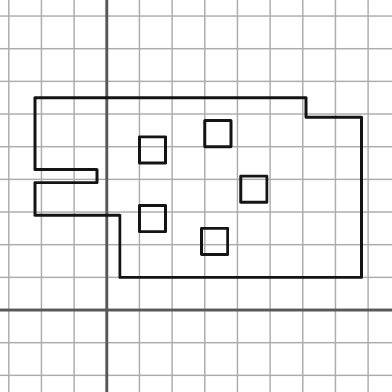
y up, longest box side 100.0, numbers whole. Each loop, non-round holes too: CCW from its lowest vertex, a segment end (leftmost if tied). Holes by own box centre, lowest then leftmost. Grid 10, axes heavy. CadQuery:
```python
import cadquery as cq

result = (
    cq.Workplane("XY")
    .moveTo(4.0, 10.0)
    .lineTo(78.0, 10.0)
    .lineTo(78.0, 59.0)
    .lineTo(61.0, 59.0)
    .lineTo(61.0, 65.0)
    .lineTo(-22.0, 65.0)
    .lineTo(-22.0, 43.0)
    .lineTo(-3.0, 43.0)
    .lineTo(-3.0, 39.0)
    .lineTo(-22.0, 39.0)
    .lineTo(-22.0, 29.0)
    .lineTo(4.0, 29.0)
    .close()
    .moveTo(29.0, 17.0)
    .lineTo(37.0, 17.0)
    .lineTo(37.0, 25.0)
    .lineTo(29.0, 25.0)
    .close()
    .moveTo(10.0, 24.0)
    .lineTo(18.0, 24.0)
    .lineTo(18.0, 32.0)
    .lineTo(10.0, 32.0)
    .close()
    .moveTo(41.0, 33.0)
    .lineTo(49.0, 33.0)
    .lineTo(49.0, 41.0)
    .lineTo(41.0, 41.0)
    .close()
    .moveTo(10.0, 45.0)
    .lineTo(18.0, 45.0)
    .lineTo(18.0, 53.0)
    .lineTo(10.0, 53.0)
    .close()
    .moveTo(30.0, 50.0)
    .lineTo(38.0, 50.0)
    .lineTo(38.0, 58.0)
    .lineTo(30.0, 58.0)
    .close()
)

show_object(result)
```